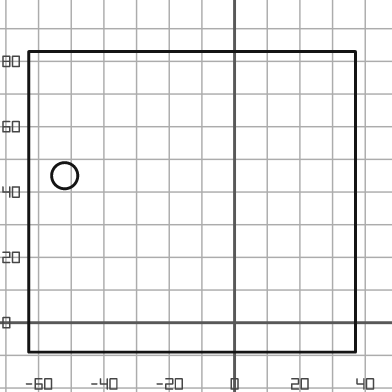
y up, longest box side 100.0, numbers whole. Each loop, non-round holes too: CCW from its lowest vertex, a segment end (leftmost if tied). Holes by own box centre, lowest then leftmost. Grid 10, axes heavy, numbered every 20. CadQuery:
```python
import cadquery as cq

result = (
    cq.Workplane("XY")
    .moveTo(-63.0, -9.0)
    .lineTo(37.0, -9.0)
    .lineTo(37.0, 83.0)
    .lineTo(-63.0, 83.0)
    .close()
    .moveTo(-52.0, 45.0)
    .circle(4.0)
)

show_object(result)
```